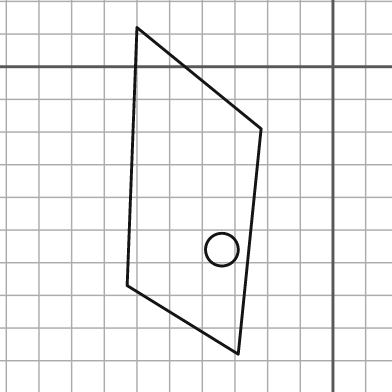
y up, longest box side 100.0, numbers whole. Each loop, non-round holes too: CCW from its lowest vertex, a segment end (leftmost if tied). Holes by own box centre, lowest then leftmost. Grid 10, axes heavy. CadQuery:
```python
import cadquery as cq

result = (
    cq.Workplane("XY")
    .moveTo(-29.0, -88.0)
    .lineTo(-22.0, -19.0)
    .lineTo(-60.0, 12.0)
    .lineTo(-63.0, -67.0)
    .close()
    .moveTo(-34.0, -56.0)
    .circle(5.0)
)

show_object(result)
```